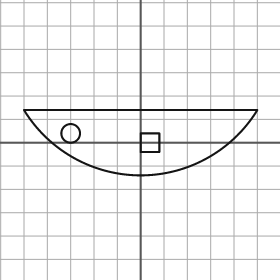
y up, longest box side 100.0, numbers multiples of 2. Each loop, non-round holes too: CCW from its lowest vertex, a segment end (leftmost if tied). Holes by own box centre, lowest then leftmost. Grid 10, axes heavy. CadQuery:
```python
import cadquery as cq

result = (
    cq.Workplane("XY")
    .moveTo(-50.0, 14.0)
    .threePointArc((0.0, -14.0), (50.0, 14.0))
    .close()
    .moveTo(0.0, -4.0)
    .lineTo(8.0, -4.0)
    .lineTo(8.0, 4.0)
    .lineTo(0.0, 4.0)
    .close()
    .moveTo(-30.0, 4.0)
    .circle(4.0)
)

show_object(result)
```